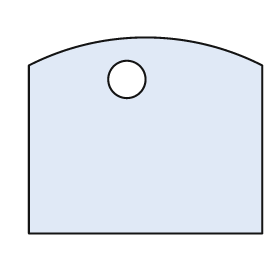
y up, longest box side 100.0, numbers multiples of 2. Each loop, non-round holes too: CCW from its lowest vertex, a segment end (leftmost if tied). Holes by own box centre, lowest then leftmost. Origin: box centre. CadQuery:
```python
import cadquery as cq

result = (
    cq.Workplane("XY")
    .moveTo(-50.0, -42.0)
    .lineTo(50.0, -42.0)
    .lineTo(50.0, 30.0)
    .threePointArc((0.0, 42.0), (-50.0, 30.0))
    .close()
    .moveTo(-8.0, 24.0)
    .circle(8.0)
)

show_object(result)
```